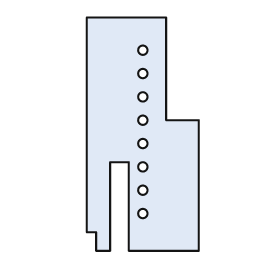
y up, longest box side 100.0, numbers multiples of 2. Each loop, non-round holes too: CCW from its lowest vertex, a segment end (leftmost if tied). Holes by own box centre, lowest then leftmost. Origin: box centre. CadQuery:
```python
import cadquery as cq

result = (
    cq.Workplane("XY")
    .moveTo(-20.0, -50.0)
    .lineTo(-14.0, -50.0)
    .lineTo(-14.0, -12.0)
    .lineTo(-6.0, -12.0)
    .lineTo(-6.0, -50.0)
    .lineTo(24.0, -50.0)
    .lineTo(24.0, 6.0)
    .lineTo(10.0, 6.0)
    .lineTo(10.0, 50.0)
    .lineTo(-24.0, 50.0)
    .lineTo(-24.0, -42.0)
    .lineTo(-20.0, -42.0)
    .close()
    .moveTo(0.0, -34.0)
    .circle(2.0)
    .moveTo(0.0, -24.0)
    .circle(2.0)
    .moveTo(0.0, -14.0)
    .circle(2.0)
    .moveTo(0.0, -4.0)
    .circle(2.0)
    .moveTo(0.0, 6.0)
    .circle(2.0)
    .moveTo(0.0, 16.0)
    .circle(2.0)
    .moveTo(0.0, 26.0)
    .circle(2.0)
    .moveTo(0.0, 36.0)
    .circle(2.0)
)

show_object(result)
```